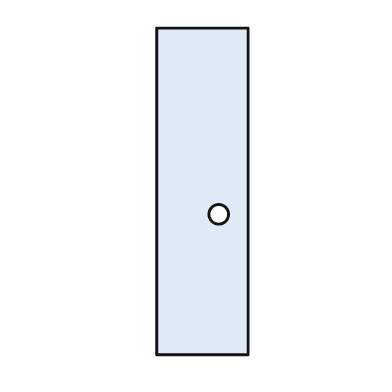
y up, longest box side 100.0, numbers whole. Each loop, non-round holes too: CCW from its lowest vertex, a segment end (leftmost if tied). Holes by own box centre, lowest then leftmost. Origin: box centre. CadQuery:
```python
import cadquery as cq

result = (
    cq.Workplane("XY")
    .moveTo(-14.0, -50.0)
    .lineTo(14.0, -50.0)
    .lineTo(14.0, 50.0)
    .lineTo(-14.0, 50.0)
    .close()
    .moveTo(5.0, -7.0)
    .circle(3.0)
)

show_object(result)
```